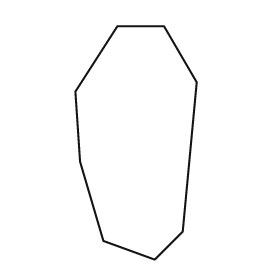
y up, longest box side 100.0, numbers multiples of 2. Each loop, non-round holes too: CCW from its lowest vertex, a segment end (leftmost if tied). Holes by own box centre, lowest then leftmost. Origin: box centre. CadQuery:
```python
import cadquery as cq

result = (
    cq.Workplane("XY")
    .moveTo(8.0, -50.0)
    .lineTo(20.0, -38.0)
    .lineTo(26.0, 26.0)
    .lineTo(12.0, 50.0)
    .lineTo(-8.0, 50.0)
    .lineTo(-26.0, 22.0)
    .lineTo(-24.0, -8.0)
    .lineTo(-14.0, -42.0)
    .close()
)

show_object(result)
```